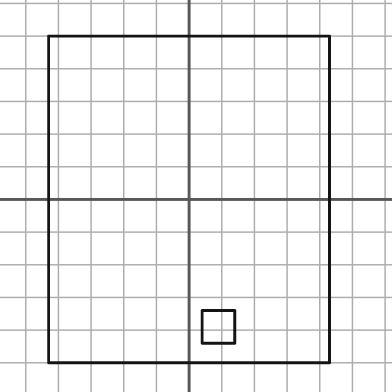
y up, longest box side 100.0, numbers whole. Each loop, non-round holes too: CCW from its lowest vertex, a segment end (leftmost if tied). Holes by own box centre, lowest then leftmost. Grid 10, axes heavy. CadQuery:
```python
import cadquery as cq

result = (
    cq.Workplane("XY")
    .moveTo(-43.0, -50.0)
    .lineTo(43.0, -50.0)
    .lineTo(43.0, 50.0)
    .lineTo(-43.0, 50.0)
    .close()
    .moveTo(4.0, -44.0)
    .lineTo(14.0, -44.0)
    .lineTo(14.0, -34.0)
    .lineTo(4.0, -34.0)
    .close()
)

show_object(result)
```